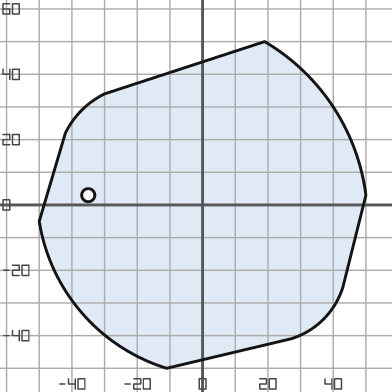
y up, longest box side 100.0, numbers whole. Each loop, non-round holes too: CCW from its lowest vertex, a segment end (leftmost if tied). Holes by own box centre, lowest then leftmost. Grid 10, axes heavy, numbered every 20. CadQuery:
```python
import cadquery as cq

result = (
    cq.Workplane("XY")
    .moveTo(-11.0, -50.0)
    .lineTo(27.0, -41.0)
    .threePointArc((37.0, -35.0), (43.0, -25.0))
    .lineTo(50.0, 3.0)
    .threePointArc((40.0, 30.0), (19.0, 50.0))
    .lineTo(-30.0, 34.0)
    .threePointArc((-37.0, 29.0), (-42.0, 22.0))
    .lineTo(-50.0, -5.0)
    .threePointArc((-37.0, -33.0), (-11.0, -50.0))
    .close()
    .moveTo(-35.0, 3.0)
    .circle(2.0)
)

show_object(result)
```